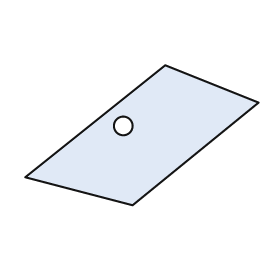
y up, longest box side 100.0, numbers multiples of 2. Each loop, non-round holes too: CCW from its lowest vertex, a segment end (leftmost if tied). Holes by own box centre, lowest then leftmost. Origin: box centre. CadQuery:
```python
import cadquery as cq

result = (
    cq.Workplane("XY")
    .moveTo(-4.0, -30.0)
    .lineTo(50.0, 14.0)
    .lineTo(10.0, 30.0)
    .lineTo(-50.0, -18.0)
    .close()
    .moveTo(-8.0, 4.0)
    .circle(4.0)
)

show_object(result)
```